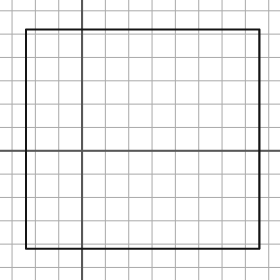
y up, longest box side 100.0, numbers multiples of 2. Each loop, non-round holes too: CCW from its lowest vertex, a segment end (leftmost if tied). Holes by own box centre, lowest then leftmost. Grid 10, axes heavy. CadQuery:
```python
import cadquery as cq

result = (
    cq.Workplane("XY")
    .moveTo(-24.0, -42.0)
    .lineTo(76.0, -42.0)
    .lineTo(76.0, 52.0)
    .lineTo(-24.0, 52.0)
    .close()
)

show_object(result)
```